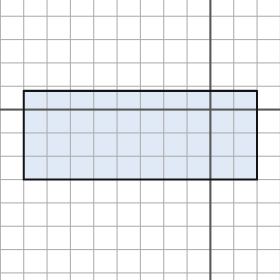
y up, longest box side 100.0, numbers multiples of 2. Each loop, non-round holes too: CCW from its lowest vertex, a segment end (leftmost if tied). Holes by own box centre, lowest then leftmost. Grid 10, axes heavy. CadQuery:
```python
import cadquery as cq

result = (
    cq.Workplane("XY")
    .moveTo(-80.0, -30.0)
    .lineTo(20.0, -30.0)
    .lineTo(20.0, 8.0)
    .lineTo(-80.0, 8.0)
    .close()
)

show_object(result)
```